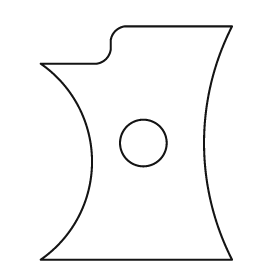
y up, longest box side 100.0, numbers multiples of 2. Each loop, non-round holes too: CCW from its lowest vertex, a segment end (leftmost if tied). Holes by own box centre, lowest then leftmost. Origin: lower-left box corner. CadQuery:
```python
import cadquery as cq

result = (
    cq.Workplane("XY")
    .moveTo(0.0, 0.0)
    .lineTo(82.0, 0.0)
    .threePointArc((70.0, 50.0), (82.0, 100.0))
    .lineTo(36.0, 100.0)
    .threePointArc((32.0, 98.0), (30.0, 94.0))
    .lineTo(30.0, 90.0)
    .threePointArc((28.0, 86.0), (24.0, 84.0))
    .lineTo(0.0, 84.0)
    .threePointArc((22.0, 42.0), (0.0, 0.0))
    .close()
    .moveTo(44.0, 50.0)
    .circle(10.0)
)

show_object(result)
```